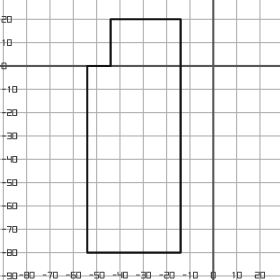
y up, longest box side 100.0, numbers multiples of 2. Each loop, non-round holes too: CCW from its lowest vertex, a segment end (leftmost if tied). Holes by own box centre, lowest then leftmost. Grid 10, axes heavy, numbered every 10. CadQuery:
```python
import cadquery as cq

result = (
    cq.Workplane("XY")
    .moveTo(-54.0, -80.0)
    .lineTo(-14.0, -80.0)
    .lineTo(-14.0, 20.0)
    .lineTo(-44.0, 20.0)
    .lineTo(-44.0, 0.0)
    .lineTo(-54.0, 0.0)
    .close()
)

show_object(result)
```